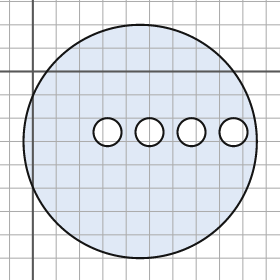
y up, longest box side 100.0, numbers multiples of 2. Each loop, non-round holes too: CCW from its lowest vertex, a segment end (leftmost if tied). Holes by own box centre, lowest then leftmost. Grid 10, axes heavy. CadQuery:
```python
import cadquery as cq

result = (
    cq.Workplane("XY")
    .moveTo(46.0, -30.0)
    .circle(50.0)
    .moveTo(32.0, -26.0)
    .circle(6.0)
    .moveTo(50.0, -26.0)
    .circle(6.0)
    .moveTo(68.0, -26.0)
    .circle(6.0)
    .moveTo(86.0, -26.0)
    .circle(6.0)
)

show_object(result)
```